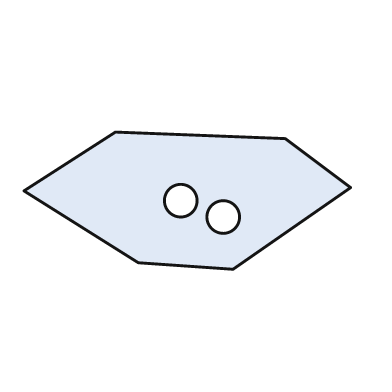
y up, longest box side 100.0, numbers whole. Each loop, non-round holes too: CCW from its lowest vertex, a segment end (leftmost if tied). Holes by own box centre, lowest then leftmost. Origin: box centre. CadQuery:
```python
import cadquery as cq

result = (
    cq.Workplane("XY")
    .moveTo(14.0, -21.0)
    .lineTo(50.0, 4.0)
    .lineTo(30.0, 19.0)
    .lineTo(-22.0, 21.0)
    .lineTo(-50.0, 3.0)
    .lineTo(-15.0, -19.0)
    .close()
    .moveTo(11.0, -5.0)
    .circle(5.0)
    .moveTo(-2.0, 0.0)
    .circle(5.0)
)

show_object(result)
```